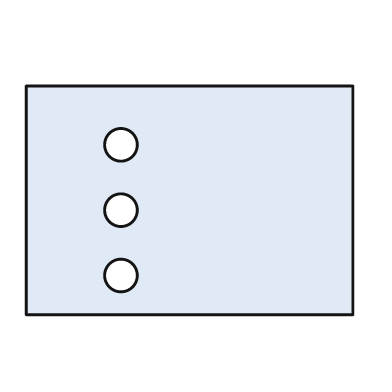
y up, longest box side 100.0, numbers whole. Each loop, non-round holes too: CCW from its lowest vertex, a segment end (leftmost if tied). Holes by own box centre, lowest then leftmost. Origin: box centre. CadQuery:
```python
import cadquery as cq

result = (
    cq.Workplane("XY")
    .moveTo(-50.0, -35.0)
    .lineTo(50.0, -35.0)
    .lineTo(50.0, 35.0)
    .lineTo(-50.0, 35.0)
    .close()
    .moveTo(-21.0, -23.0)
    .circle(5.0)
    .moveTo(-21.0, -3.0)
    .circle(5.0)
    .moveTo(-21.0, 17.0)
    .circle(5.0)
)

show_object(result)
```